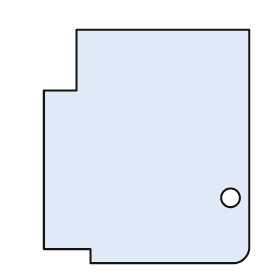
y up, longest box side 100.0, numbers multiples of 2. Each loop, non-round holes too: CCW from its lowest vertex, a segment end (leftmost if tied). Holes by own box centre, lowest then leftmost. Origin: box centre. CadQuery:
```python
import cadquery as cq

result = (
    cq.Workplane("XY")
    .moveTo(-24.0, -50.0)
    .lineTo(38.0, -50.0)
    .threePointArc((42.0, -48.0), (44.0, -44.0))
    .lineTo(44.0, 50.0)
    .lineTo(-30.0, 50.0)
    .lineTo(-30.0, 24.0)
    .lineTo(-44.0, 24.0)
    .lineTo(-44.0, -44.0)
    .lineTo(-24.0, -44.0)
    .close()
    .moveTo(36.0, -22.0)
    .circle(4.0)
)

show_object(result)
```